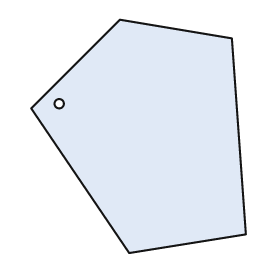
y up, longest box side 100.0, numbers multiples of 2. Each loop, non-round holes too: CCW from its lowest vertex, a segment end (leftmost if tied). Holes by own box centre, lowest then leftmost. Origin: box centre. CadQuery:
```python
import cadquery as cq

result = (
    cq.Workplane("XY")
    .moveTo(-4.0, -50.0)
    .lineTo(46.0, -42.0)
    .lineTo(40.0, 42.0)
    .lineTo(-8.0, 50.0)
    .lineTo(-46.0, 12.0)
    .close()
    .moveTo(-34.0, 14.0)
    .circle(2.0)
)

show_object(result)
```